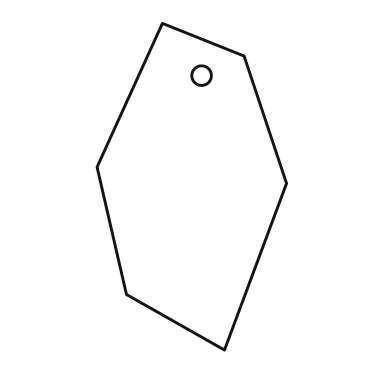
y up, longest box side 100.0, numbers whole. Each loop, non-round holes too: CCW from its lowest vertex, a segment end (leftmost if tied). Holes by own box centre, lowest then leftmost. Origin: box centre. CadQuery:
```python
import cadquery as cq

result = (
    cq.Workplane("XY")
    .moveTo(10.0, -50.0)
    .lineTo(29.0, 1.0)
    .lineTo(16.0, 40.0)
    .lineTo(-9.0, 50.0)
    .lineTo(-29.0, 6.0)
    .lineTo(-20.0, -33.0)
    .close()
    .moveTo(3.0, 34.0)
    .circle(3.0)
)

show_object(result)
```